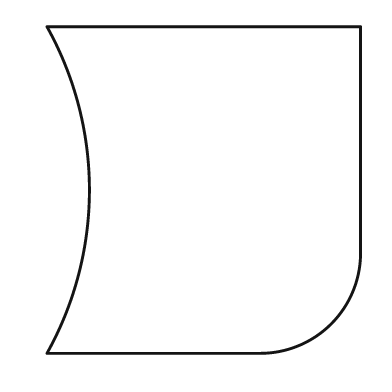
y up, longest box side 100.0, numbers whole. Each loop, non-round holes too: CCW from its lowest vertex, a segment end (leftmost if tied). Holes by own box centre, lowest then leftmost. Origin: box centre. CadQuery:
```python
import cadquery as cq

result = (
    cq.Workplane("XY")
    .moveTo(-48.0, -50.0)
    .lineTo(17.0, -50.0)
    .threePointArc((39.0, -41.0), (48.0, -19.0))
    .lineTo(48.0, 50.0)
    .lineTo(-48.0, 50.0)
    .threePointArc((-35.0, 0.0), (-48.0, -50.0))
    .close()
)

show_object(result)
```